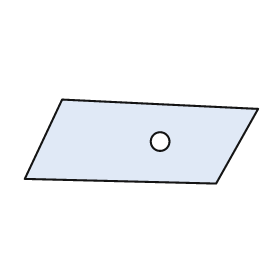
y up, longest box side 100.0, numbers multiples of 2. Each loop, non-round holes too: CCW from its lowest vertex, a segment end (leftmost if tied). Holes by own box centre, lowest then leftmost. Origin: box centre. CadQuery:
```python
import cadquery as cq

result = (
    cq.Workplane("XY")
    .moveTo(32.0, -18.0)
    .lineTo(50.0, 14.0)
    .lineTo(-34.0, 18.0)
    .lineTo(-50.0, -16.0)
    .close()
    .moveTo(8.0, 0.0)
    .circle(4.0)
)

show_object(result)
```